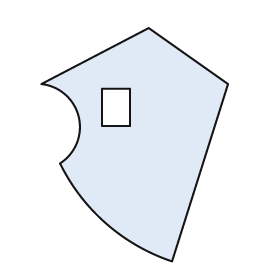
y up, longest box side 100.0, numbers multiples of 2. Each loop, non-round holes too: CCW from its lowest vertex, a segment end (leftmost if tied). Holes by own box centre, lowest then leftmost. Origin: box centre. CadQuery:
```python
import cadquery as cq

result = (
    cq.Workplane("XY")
    .moveTo(16.0, -50.0)
    .lineTo(40.0, 26.0)
    .lineTo(6.0, 50.0)
    .lineTo(-40.0, 26.0)
    .threePointArc((-24.0, 12.0), (-32.0, -8.0))
    .threePointArc((-12.0, -34.0), (16.0, -50.0))
    .close()
    .moveTo(-14.0, 8.0)
    .lineTo(-2.0, 8.0)
    .lineTo(-2.0, 24.0)
    .lineTo(-14.0, 24.0)
    .close()
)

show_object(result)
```